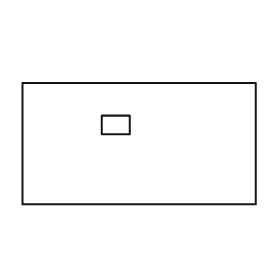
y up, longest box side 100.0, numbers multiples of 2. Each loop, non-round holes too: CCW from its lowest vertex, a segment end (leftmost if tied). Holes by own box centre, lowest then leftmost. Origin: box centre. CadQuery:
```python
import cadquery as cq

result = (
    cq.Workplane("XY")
    .moveTo(-50.0, -26.0)
    .lineTo(50.0, -26.0)
    .lineTo(50.0, 26.0)
    .lineTo(-50.0, 26.0)
    .close()
    .moveTo(-16.0, 4.0)
    .lineTo(-4.0, 4.0)
    .lineTo(-4.0, 12.0)
    .lineTo(-16.0, 12.0)
    .close()
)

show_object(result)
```